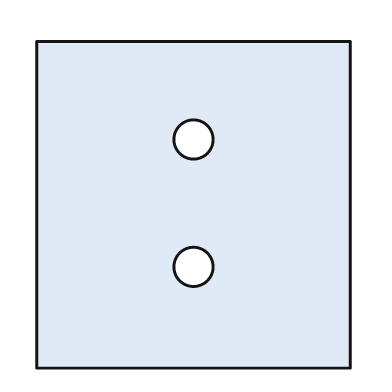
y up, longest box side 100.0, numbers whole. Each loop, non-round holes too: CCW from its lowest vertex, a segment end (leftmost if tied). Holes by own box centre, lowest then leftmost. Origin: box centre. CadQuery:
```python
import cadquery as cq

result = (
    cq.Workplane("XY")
    .moveTo(-48.0, -50.0)
    .lineTo(48.0, -50.0)
    .lineTo(48.0, 50.0)
    .lineTo(-48.0, 50.0)
    .close()
    .moveTo(0.0, -19.0)
    .circle(6.0)
    .moveTo(0.0, 20.0)
    .circle(6.0)
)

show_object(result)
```